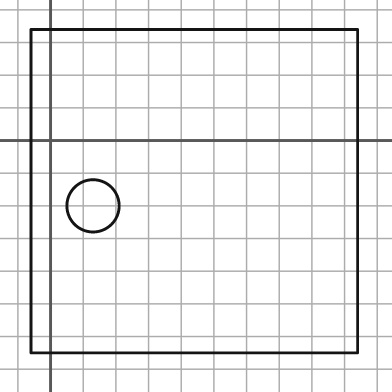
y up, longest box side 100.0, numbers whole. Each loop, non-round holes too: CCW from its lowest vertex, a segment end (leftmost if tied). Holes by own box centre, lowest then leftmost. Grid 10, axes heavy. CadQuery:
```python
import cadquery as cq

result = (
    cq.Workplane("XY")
    .moveTo(-6.0, -65.0)
    .lineTo(94.0, -65.0)
    .lineTo(94.0, 34.0)
    .lineTo(-6.0, 34.0)
    .close()
    .moveTo(13.0, -20.0)
    .circle(8.0)
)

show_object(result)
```